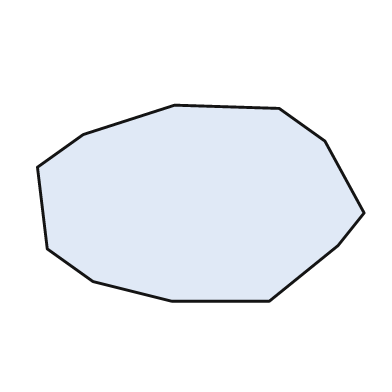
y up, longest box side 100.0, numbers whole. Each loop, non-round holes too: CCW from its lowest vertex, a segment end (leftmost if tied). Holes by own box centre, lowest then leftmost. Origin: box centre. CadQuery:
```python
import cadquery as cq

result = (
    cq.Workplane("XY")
    .moveTo(-9.0, -30.0)
    .lineTo(21.0, -30.0)
    .lineTo(42.0, -13.0)
    .lineTo(50.0, -3.0)
    .lineTo(38.0, 19.0)
    .lineTo(24.0, 29.0)
    .lineTo(-8.0, 30.0)
    .lineTo(-36.0, 21.0)
    .lineTo(-50.0, 11.0)
    .lineTo(-47.0, -14.0)
    .lineTo(-33.0, -24.0)
    .close()
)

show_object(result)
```